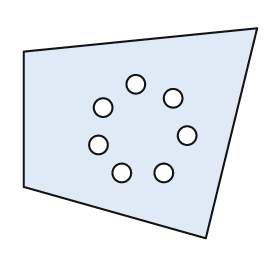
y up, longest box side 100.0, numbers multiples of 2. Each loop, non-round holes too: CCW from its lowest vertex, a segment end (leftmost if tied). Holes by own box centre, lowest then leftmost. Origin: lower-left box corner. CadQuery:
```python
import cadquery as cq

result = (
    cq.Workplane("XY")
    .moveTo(78.0, 0.0)
    .lineTo(100.0, 90.0)
    .lineTo(0.0, 80.0)
    .lineTo(0.0, 22.0)
    .close()
    .moveTo(42.0, 28.0)
    .circle(4.0)
    .moveTo(60.0, 28.0)
    .circle(4.0)
    .moveTo(32.0, 40.0)
    .circle(4.0)
    .moveTo(70.0, 44.0)
    .circle(4.0)
    .moveTo(34.0, 56.0)
    .circle(4.0)
    .moveTo(64.0, 60.0)
    .circle(4.0)
    .moveTo(48.0, 66.0)
    .circle(4.0)
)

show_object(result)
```